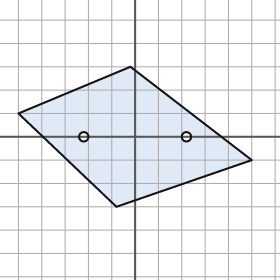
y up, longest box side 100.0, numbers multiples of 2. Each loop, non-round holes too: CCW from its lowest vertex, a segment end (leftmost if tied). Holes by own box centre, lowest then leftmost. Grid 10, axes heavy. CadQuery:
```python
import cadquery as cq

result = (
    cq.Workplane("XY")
    .moveTo(-8.0, -30.0)
    .lineTo(50.0, -10.0)
    .lineTo(-2.0, 30.0)
    .lineTo(-50.0, 10.0)
    .close()
    .moveTo(-22.0, 0.0)
    .circle(2.0)
    .moveTo(22.0, 0.0)
    .circle(2.0)
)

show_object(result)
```